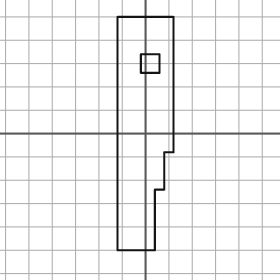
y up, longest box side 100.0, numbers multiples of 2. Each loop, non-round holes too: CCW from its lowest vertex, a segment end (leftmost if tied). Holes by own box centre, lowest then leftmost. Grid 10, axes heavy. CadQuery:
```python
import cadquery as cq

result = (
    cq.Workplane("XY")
    .moveTo(-12.0, -50.0)
    .lineTo(4.0, -50.0)
    .lineTo(4.0, -24.0)
    .lineTo(8.0, -24.0)
    .lineTo(8.0, -8.0)
    .lineTo(12.0, -8.0)
    .lineTo(12.0, 50.0)
    .lineTo(-12.0, 50.0)
    .close()
    .moveTo(-2.0, 26.0)
    .lineTo(6.0, 26.0)
    .lineTo(6.0, 34.0)
    .lineTo(-2.0, 34.0)
    .close()
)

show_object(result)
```